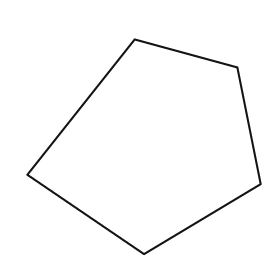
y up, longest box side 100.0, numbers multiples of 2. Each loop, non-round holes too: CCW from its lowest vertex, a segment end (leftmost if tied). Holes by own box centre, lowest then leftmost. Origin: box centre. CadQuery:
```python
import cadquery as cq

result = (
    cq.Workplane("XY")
    .moveTo(0.0, -46.0)
    .lineTo(50.0, -16.0)
    .lineTo(40.0, 34.0)
    .lineTo(-4.0, 46.0)
    .lineTo(-50.0, -12.0)
    .close()
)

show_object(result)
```